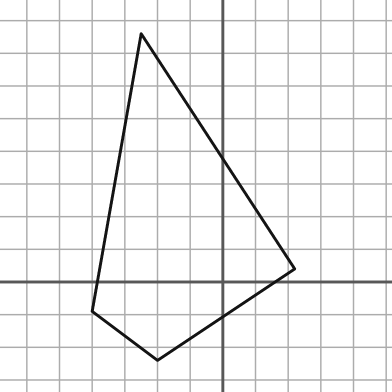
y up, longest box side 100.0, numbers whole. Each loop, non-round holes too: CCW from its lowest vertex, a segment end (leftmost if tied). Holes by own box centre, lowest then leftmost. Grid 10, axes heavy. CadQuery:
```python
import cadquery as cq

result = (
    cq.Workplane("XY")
    .moveTo(-20.0, -24.0)
    .lineTo(22.0, 4.0)
    .lineTo(-25.0, 76.0)
    .lineTo(-40.0, -9.0)
    .close()
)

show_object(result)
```